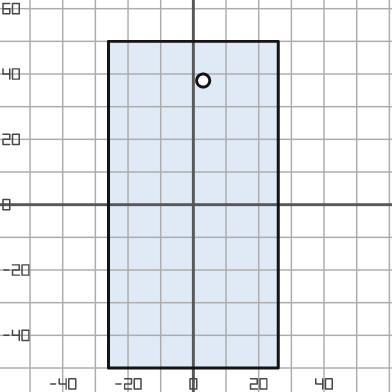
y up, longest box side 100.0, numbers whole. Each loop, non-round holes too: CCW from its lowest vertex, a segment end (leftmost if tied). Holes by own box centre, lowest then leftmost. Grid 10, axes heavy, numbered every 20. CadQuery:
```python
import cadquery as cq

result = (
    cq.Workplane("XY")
    .moveTo(-26.0, -50.0)
    .lineTo(26.0, -50.0)
    .lineTo(26.0, 50.0)
    .lineTo(-26.0, 50.0)
    .close()
    .moveTo(3.0, 38.0)
    .circle(2.0)
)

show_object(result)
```